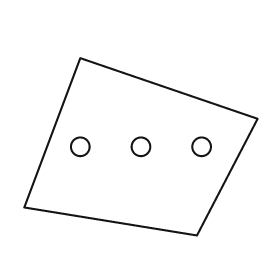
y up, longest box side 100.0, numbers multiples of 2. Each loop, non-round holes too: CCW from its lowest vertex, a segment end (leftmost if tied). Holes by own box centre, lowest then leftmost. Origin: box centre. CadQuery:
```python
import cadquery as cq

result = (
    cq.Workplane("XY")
    .moveTo(24.0, -38.0)
    .lineTo(50.0, 12.0)
    .lineTo(-26.0, 38.0)
    .lineTo(-50.0, -26.0)
    .close()
    .moveTo(-26.0, 0.0)
    .circle(4.0)
    .moveTo(0.0, 0.0)
    .circle(4.0)
    .moveTo(26.0, 0.0)
    .circle(4.0)
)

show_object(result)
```